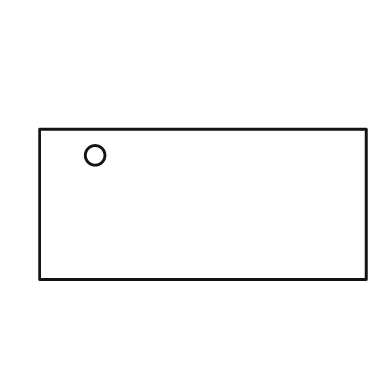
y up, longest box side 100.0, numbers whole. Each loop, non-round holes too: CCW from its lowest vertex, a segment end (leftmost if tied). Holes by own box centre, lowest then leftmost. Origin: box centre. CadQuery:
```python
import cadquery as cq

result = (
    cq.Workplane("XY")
    .moveTo(-50.0, -23.0)
    .lineTo(50.0, -23.0)
    .lineTo(50.0, 23.0)
    .lineTo(-50.0, 23.0)
    .close()
    .moveTo(-33.0, 15.0)
    .circle(3.0)
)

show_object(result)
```